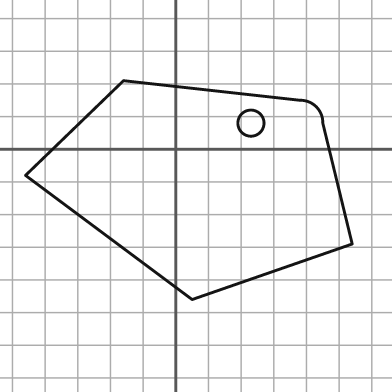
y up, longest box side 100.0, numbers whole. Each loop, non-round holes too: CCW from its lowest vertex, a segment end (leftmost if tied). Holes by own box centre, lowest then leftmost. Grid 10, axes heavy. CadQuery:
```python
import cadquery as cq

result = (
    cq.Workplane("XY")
    .moveTo(5.0, -46.0)
    .lineTo(54.0, -29.0)
    .lineTo(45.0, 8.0)
    .threePointArc((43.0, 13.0), (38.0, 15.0))
    .lineTo(-16.0, 21.0)
    .lineTo(-46.0, -8.0)
    .close()
    .moveTo(23.0, 8.0)
    .circle(4.0)
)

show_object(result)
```